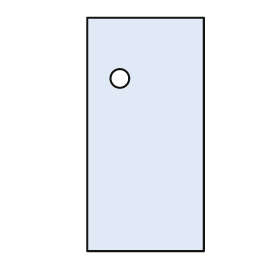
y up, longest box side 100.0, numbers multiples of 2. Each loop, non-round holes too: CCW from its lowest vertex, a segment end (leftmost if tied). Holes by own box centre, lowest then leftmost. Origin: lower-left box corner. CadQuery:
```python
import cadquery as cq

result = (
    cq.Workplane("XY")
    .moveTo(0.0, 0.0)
    .lineTo(50.0, 0.0)
    .lineTo(50.0, 100.0)
    .lineTo(0.0, 100.0)
    .close()
    .moveTo(14.0, 74.0)
    .circle(4.0)
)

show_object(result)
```